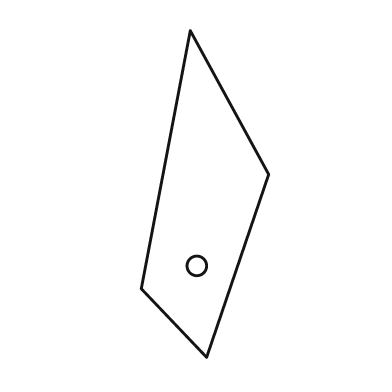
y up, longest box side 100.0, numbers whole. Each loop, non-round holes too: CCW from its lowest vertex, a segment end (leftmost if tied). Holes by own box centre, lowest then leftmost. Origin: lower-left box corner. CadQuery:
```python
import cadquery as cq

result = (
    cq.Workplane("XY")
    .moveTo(20.0, 0.0)
    .lineTo(39.0, 56.0)
    .lineTo(15.0, 100.0)
    .lineTo(0.0, 21.0)
    .close()
    .moveTo(17.0, 28.0)
    .circle(3.0)
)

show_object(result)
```